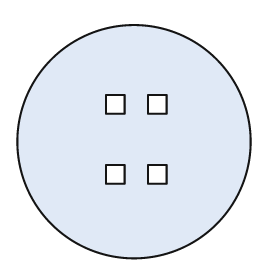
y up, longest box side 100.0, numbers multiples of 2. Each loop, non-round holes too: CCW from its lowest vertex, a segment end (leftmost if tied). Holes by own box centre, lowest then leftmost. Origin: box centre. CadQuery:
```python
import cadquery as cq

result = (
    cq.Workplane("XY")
    .moveTo(0.0, 0.0)
    .circle(50.0)
    .moveTo(-12.0, -18.0)
    .lineTo(-4.0, -18.0)
    .lineTo(-4.0, -10.0)
    .lineTo(-12.0, -10.0)
    .close()
    .moveTo(6.0, -18.0)
    .lineTo(14.0, -18.0)
    .lineTo(14.0, -10.0)
    .lineTo(6.0, -10.0)
    .close()
    .moveTo(-12.0, 12.0)
    .lineTo(-4.0, 12.0)
    .lineTo(-4.0, 20.0)
    .lineTo(-12.0, 20.0)
    .close()
    .moveTo(6.0, 12.0)
    .lineTo(14.0, 12.0)
    .lineTo(14.0, 20.0)
    .lineTo(6.0, 20.0)
    .close()
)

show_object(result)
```